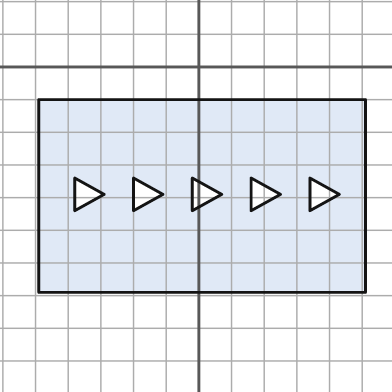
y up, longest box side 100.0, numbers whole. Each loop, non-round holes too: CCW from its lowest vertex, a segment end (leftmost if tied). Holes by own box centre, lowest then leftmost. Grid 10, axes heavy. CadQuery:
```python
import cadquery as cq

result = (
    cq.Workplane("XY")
    .moveTo(-49.0, -69.0)
    .lineTo(51.0, -69.0)
    .lineTo(51.0, -10.0)
    .lineTo(-49.0, -10.0)
    .close()
    .moveTo(-38.0, -44.0)
    .lineTo(-29.0, -39.0)
    .lineTo(-38.0, -34.0)
    .close()
    .moveTo(-20.0, -44.0)
    .lineTo(-11.0, -39.0)
    .lineTo(-20.0, -34.0)
    .close()
    .moveTo(-2.0, -44.0)
    .lineTo(7.0, -39.0)
    .lineTo(-2.0, -34.0)
    .close()
    .moveTo(16.0, -44.0)
    .lineTo(25.0, -39.0)
    .lineTo(16.0, -34.0)
    .close()
    .moveTo(34.0, -44.0)
    .lineTo(43.0, -39.0)
    .lineTo(34.0, -34.0)
    .close()
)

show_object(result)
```